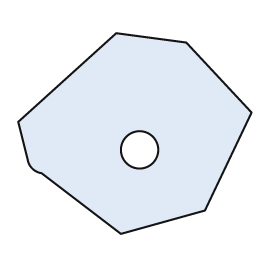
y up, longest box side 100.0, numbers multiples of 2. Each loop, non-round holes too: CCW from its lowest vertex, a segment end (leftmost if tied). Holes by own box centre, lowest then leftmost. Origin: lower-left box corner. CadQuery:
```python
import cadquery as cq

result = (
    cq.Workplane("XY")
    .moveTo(44.0, 0.0)
    .lineTo(80.0, 10.0)
    .lineTo(100.0, 52.0)
    .lineTo(72.0, 82.0)
    .lineTo(42.0, 86.0)
    .lineTo(0.0, 48.0)
    .lineTo(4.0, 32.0)
    .threePointArc((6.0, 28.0), (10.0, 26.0))
    .close()
    .moveTo(52.0, 36.0)
    .circle(8.0)
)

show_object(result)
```